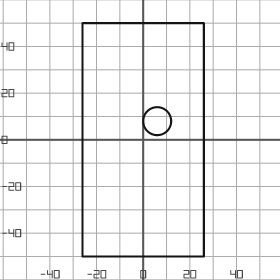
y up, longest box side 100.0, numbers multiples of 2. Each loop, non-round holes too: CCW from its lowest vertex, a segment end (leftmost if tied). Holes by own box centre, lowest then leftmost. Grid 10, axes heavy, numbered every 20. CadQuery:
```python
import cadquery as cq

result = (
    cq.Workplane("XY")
    .moveTo(-26.0, -50.0)
    .lineTo(26.0, -50.0)
    .lineTo(26.0, 50.0)
    .lineTo(-26.0, 50.0)
    .close()
    .moveTo(6.0, 8.0)
    .circle(6.0)
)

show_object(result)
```